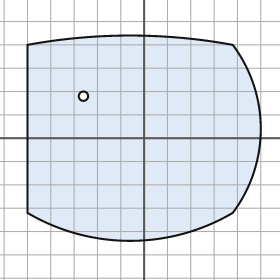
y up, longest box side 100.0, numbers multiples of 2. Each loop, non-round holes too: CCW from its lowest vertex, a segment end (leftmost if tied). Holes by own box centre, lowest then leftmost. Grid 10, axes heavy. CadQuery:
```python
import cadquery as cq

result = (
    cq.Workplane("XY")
    .moveTo(-50.0, -32.0)
    .threePointArc((-6.0, -44.0), (38.0, -32.0))
    .threePointArc((50.0, 4.0), (38.0, 40.0))
    .threePointArc((-6.0, 44.0), (-50.0, 40.0))
    .close()
    .moveTo(-26.0, 18.0)
    .circle(2.0)
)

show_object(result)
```